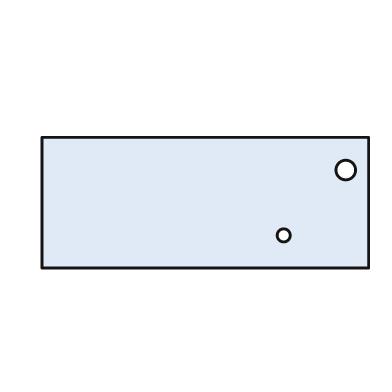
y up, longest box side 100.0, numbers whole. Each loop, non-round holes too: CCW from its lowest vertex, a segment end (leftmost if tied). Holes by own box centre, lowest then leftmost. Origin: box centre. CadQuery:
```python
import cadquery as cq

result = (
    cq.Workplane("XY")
    .moveTo(-50.0, -20.0)
    .lineTo(50.0, -20.0)
    .lineTo(50.0, 20.0)
    .lineTo(-50.0, 20.0)
    .close()
    .moveTo(24.0, -10.0)
    .circle(2.0)
    .moveTo(43.0, 10.0)
    .circle(3.0)
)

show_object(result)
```